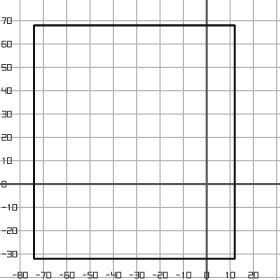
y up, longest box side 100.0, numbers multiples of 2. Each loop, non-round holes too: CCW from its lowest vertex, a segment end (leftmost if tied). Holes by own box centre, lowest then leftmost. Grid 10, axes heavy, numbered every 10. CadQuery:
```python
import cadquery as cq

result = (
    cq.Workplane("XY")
    .moveTo(-74.0, -32.0)
    .lineTo(12.0, -32.0)
    .lineTo(12.0, 68.0)
    .lineTo(-74.0, 68.0)
    .close()
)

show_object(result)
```